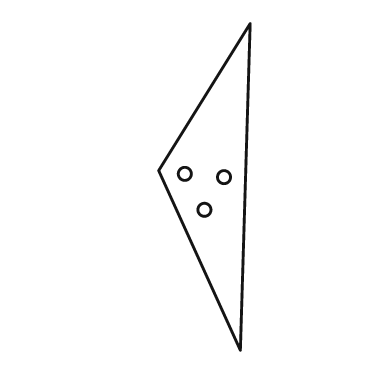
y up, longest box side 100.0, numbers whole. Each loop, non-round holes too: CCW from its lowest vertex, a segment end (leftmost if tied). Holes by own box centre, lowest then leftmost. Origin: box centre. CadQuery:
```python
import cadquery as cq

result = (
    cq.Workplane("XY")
    .moveTo(11.0, -50.0)
    .lineTo(14.0, 50.0)
    .lineTo(-14.0, 5.0)
    .close()
    .moveTo(0.0, -7.0)
    .circle(2.0)
    .moveTo(6.0, 3.0)
    .circle(2.0)
    .moveTo(-6.0, 4.0)
    .circle(2.0)
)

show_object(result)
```